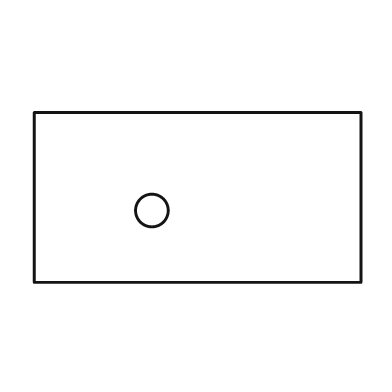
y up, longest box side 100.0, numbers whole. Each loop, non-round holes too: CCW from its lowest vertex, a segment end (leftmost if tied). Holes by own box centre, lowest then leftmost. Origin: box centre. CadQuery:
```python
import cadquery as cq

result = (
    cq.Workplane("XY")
    .moveTo(-50.0, -26.0)
    .lineTo(50.0, -26.0)
    .lineTo(50.0, 26.0)
    .lineTo(-50.0, 26.0)
    .close()
    .moveTo(-14.0, -4.0)
    .circle(5.0)
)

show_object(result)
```